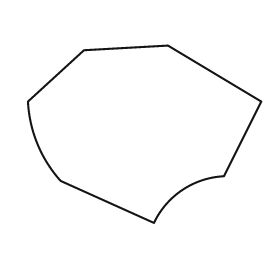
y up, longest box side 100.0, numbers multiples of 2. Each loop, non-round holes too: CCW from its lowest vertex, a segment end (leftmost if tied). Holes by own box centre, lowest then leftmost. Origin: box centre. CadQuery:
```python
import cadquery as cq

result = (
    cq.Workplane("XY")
    .moveTo(4.0, -38.0)
    .threePointArc((16.0, -24.0), (34.0, -18.0))
    .lineTo(50.0, 14.0)
    .lineTo(10.0, 38.0)
    .lineTo(-26.0, 36.0)
    .lineTo(-50.0, 14.0)
    .threePointArc((-46.0, -4.0), (-36.0, -20.0))
    .close()
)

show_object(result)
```